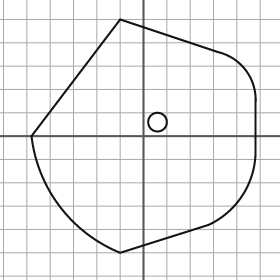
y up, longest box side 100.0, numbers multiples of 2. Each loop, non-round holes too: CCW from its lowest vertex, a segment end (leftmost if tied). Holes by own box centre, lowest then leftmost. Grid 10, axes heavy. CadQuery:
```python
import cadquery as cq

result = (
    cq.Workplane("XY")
    .moveTo(-10.0, -50.0)
    .lineTo(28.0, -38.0)
    .threePointArc((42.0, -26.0), (48.0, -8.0))
    .lineTo(48.0, 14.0)
    .threePointArc((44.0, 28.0), (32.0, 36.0))
    .lineTo(-10.0, 50.0)
    .lineTo(-48.0, 0.0)
    .threePointArc((-36.0, -30.0), (-10.0, -50.0))
    .close()
    .moveTo(6.0, 6.0)
    .circle(4.0)
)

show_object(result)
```